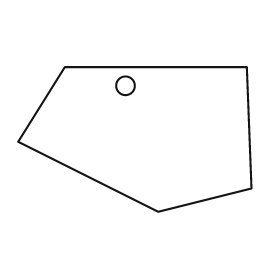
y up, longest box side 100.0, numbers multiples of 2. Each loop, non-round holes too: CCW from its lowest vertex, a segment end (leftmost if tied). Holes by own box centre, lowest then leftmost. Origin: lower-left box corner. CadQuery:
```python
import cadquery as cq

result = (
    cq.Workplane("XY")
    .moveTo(60.0, 0.0)
    .lineTo(100.0, 10.0)
    .lineTo(98.0, 62.0)
    .lineTo(20.0, 62.0)
    .lineTo(0.0, 30.0)
    .close()
    .moveTo(46.0, 54.0)
    .circle(4.0)
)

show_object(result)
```